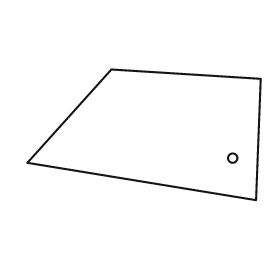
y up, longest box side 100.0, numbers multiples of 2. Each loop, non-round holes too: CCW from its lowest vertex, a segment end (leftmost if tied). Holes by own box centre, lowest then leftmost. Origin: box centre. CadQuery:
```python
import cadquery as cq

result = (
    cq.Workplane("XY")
    .moveTo(48.0, -28.0)
    .lineTo(50.0, 24.0)
    .lineTo(-14.0, 28.0)
    .lineTo(-50.0, -12.0)
    .close()
    .moveTo(38.0, -10.0)
    .circle(2.0)
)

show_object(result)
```